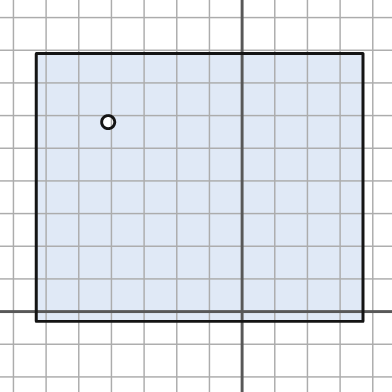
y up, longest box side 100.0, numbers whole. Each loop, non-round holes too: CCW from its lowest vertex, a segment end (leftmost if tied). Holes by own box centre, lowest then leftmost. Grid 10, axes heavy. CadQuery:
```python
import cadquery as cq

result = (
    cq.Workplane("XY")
    .moveTo(-63.0, -3.0)
    .lineTo(37.0, -3.0)
    .lineTo(37.0, 79.0)
    .lineTo(-63.0, 79.0)
    .close()
    .moveTo(-41.0, 58.0)
    .circle(2.0)
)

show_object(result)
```